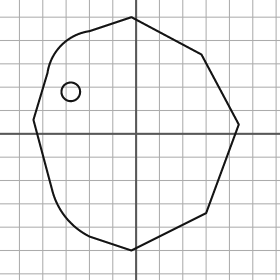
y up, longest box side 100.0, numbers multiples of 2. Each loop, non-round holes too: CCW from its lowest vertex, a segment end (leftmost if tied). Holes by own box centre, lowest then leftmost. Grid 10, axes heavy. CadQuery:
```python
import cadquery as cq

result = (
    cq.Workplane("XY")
    .moveTo(-2.0, -50.0)
    .lineTo(30.0, -34.0)
    .lineTo(44.0, 4.0)
    .lineTo(28.0, 34.0)
    .lineTo(-2.0, 50.0)
    .lineTo(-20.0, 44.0)
    .threePointArc((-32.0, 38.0), (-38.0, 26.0))
    .lineTo(-44.0, 6.0)
    .lineTo(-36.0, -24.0)
    .threePointArc((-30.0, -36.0), (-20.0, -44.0))
    .close()
    .moveTo(-28.0, 18.0)
    .circle(4.0)
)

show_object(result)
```